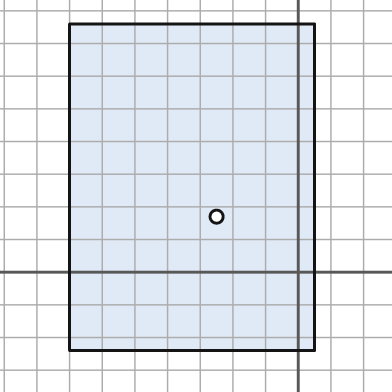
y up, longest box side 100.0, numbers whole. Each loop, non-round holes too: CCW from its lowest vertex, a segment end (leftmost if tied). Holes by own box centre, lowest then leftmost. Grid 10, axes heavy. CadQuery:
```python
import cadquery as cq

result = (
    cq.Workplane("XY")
    .moveTo(-70.0, -24.0)
    .lineTo(5.0, -24.0)
    .lineTo(5.0, 76.0)
    .lineTo(-70.0, 76.0)
    .close()
    .moveTo(-25.0, 17.0)
    .circle(2.0)
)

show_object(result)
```